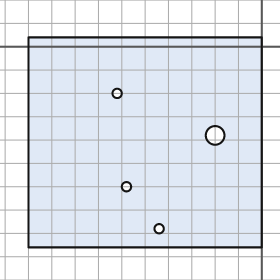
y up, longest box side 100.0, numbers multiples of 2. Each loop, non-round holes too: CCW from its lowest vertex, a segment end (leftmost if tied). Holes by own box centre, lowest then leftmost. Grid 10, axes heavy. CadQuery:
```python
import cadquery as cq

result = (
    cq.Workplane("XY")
    .moveTo(-100.0, -86.0)
    .lineTo(0.0, -86.0)
    .lineTo(0.0, 4.0)
    .lineTo(-100.0, 4.0)
    .close()
    .moveTo(-44.0, -78.0)
    .circle(2.0)
    .moveTo(-58.0, -60.0)
    .circle(2.0)
    .moveTo(-20.0, -38.0)
    .circle(4.0)
    .moveTo(-62.0, -20.0)
    .circle(2.0)
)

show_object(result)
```